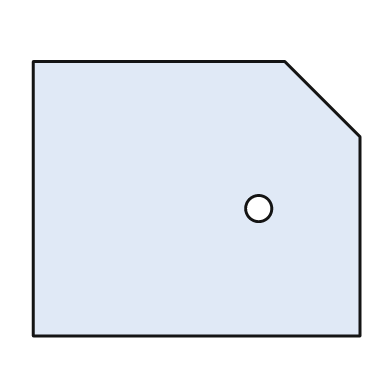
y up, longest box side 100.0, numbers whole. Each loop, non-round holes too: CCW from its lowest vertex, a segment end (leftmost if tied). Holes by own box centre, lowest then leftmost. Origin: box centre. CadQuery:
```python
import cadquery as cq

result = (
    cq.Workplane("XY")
    .moveTo(-50.0, -42.0)
    .lineTo(50.0, -42.0)
    .lineTo(50.0, 19.0)
    .lineTo(27.0, 42.0)
    .lineTo(-50.0, 42.0)
    .close()
    .moveTo(19.0, -3.0)
    .circle(4.0)
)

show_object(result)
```